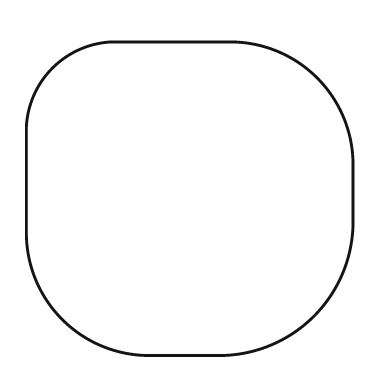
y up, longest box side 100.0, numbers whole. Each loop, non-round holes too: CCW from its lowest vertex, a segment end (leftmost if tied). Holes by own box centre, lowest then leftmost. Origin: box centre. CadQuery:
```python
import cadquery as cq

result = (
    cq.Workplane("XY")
    .moveTo(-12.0, -48.0)
    .lineTo(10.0, -48.0)
    .threePointArc((38.0, -36.0), (50.0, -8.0))
    .lineTo(50.0, 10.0)
    .threePointArc((39.0, 37.0), (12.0, 48.0))
    .lineTo(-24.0, 48.0)
    .threePointArc((-42.0, 40.0), (-50.0, 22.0))
    .lineTo(-50.0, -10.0)
    .threePointArc((-39.0, -37.0), (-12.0, -48.0))
    .close()
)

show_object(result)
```